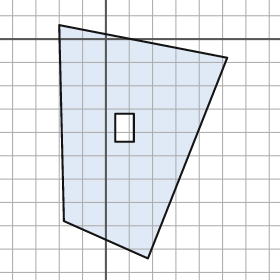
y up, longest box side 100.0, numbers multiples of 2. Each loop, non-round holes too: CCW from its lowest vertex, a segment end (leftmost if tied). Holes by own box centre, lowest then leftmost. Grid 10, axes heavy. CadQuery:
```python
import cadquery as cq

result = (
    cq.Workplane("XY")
    .moveTo(18.0, -94.0)
    .lineTo(52.0, -8.0)
    .lineTo(-20.0, 6.0)
    .lineTo(-18.0, -78.0)
    .close()
    .moveTo(4.0, -44.0)
    .lineTo(12.0, -44.0)
    .lineTo(12.0, -32.0)
    .lineTo(4.0, -32.0)
    .close()
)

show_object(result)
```